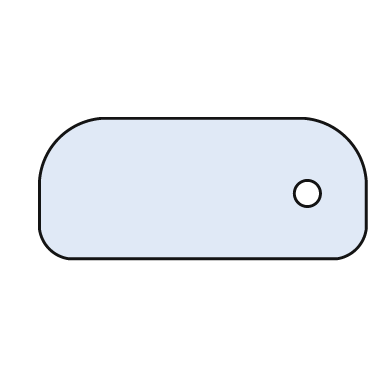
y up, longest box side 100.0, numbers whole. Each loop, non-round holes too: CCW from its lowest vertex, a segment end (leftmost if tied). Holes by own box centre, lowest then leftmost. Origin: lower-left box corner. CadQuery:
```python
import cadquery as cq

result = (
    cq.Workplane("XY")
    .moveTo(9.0, 0.0)
    .lineTo(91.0, 0.0)
    .threePointArc((97.0, 3.0), (100.0, 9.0))
    .lineTo(100.0, 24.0)
    .threePointArc((94.0, 37.0), (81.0, 43.0))
    .lineTo(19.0, 43.0)
    .threePointArc((6.0, 37.0), (0.0, 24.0))
    .lineTo(0.0, 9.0)
    .threePointArc((3.0, 3.0), (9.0, 0.0))
    .close()
    .moveTo(82.0, 20.0)
    .circle(4.0)
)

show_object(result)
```